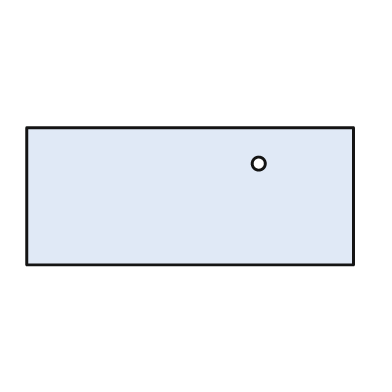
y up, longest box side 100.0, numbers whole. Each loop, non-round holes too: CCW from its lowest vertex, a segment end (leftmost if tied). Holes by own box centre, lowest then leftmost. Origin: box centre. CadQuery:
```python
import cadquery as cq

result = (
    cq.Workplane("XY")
    .moveTo(-50.0, -21.0)
    .lineTo(50.0, -21.0)
    .lineTo(50.0, 21.0)
    .lineTo(-50.0, 21.0)
    .close()
    .moveTo(21.0, 10.0)
    .circle(2.0)
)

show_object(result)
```